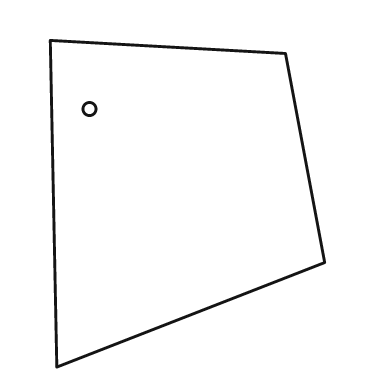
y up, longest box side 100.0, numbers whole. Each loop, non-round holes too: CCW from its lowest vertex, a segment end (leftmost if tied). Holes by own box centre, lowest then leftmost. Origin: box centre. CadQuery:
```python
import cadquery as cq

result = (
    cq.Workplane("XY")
    .moveTo(-40.0, -50.0)
    .lineTo(42.0, -18.0)
    .lineTo(30.0, 46.0)
    .lineTo(-42.0, 50.0)
    .close()
    .moveTo(-30.0, 29.0)
    .circle(2.0)
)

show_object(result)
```